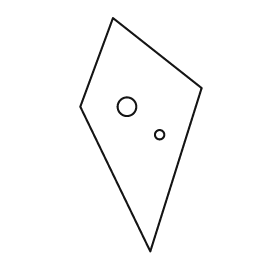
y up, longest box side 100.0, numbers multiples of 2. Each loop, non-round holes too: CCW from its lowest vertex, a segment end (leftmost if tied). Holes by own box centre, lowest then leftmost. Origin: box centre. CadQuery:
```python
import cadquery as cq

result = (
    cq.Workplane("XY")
    .moveTo(4.0, -50.0)
    .lineTo(26.0, 20.0)
    .lineTo(-12.0, 50.0)
    .lineTo(-26.0, 12.0)
    .close()
    .moveTo(8.0, 0.0)
    .circle(2.0)
    .moveTo(-6.0, 12.0)
    .circle(4.0)
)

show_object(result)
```